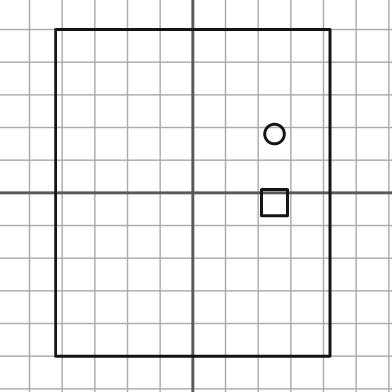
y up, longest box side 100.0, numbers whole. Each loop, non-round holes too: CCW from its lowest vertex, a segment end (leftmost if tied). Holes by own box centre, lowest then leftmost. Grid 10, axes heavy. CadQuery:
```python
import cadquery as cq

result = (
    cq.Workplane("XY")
    .moveTo(-42.0, -50.0)
    .lineTo(42.0, -50.0)
    .lineTo(42.0, 50.0)
    .lineTo(-42.0, 50.0)
    .close()
    .moveTo(21.0, -7.0)
    .lineTo(29.0, -7.0)
    .lineTo(29.0, 1.0)
    .lineTo(21.0, 1.0)
    .close()
    .moveTo(25.0, 18.0)
    .circle(3.0)
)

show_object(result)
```